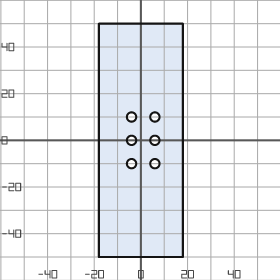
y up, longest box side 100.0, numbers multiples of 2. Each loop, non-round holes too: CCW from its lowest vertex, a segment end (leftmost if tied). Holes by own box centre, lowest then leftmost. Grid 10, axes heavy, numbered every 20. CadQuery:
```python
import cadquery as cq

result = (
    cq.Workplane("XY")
    .moveTo(-18.0, -50.0)
    .lineTo(18.0, -50.0)
    .lineTo(18.0, 50.0)
    .lineTo(-18.0, 50.0)
    .close()
    .moveTo(-4.0, -10.0)
    .circle(2.0)
    .moveTo(6.0, -10.0)
    .circle(2.0)
    .moveTo(-4.0, 0.0)
    .circle(2.0)
    .moveTo(6.0, 0.0)
    .circle(2.0)
    .moveTo(-4.0, 10.0)
    .circle(2.0)
    .moveTo(6.0, 10.0)
    .circle(2.0)
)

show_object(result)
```